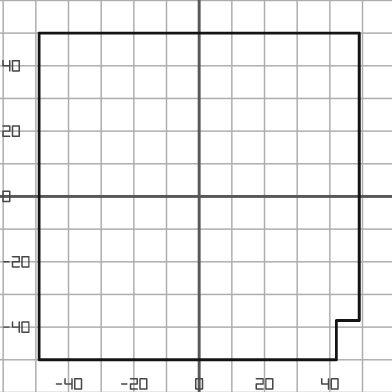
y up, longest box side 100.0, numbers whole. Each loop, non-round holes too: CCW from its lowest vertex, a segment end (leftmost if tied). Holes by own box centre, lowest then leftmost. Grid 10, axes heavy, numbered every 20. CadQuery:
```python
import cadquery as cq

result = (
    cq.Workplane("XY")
    .moveTo(-49.0, -50.0)
    .lineTo(42.0, -50.0)
    .lineTo(42.0, -38.0)
    .lineTo(49.0, -38.0)
    .lineTo(49.0, 50.0)
    .lineTo(-49.0, 50.0)
    .close()
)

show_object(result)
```